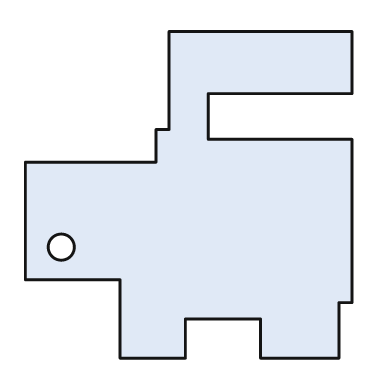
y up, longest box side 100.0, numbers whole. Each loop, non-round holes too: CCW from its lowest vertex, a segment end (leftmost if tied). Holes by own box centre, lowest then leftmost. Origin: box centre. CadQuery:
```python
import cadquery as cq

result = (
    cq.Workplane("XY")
    .moveTo(-21.0, -50.0)
    .lineTo(-1.0, -50.0)
    .lineTo(-1.0, -38.0)
    .lineTo(22.0, -38.0)
    .lineTo(22.0, -50.0)
    .lineTo(46.0, -50.0)
    .lineTo(46.0, -33.0)
    .lineTo(50.0, -33.0)
    .lineTo(50.0, 17.0)
    .lineTo(6.0, 17.0)
    .lineTo(6.0, 31.0)
    .lineTo(50.0, 31.0)
    .lineTo(50.0, 50.0)
    .lineTo(-6.0, 50.0)
    .lineTo(-6.0, 20.0)
    .lineTo(-10.0, 20.0)
    .lineTo(-10.0, 10.0)
    .lineTo(-50.0, 10.0)
    .lineTo(-50.0, -26.0)
    .lineTo(-21.0, -26.0)
    .close()
    .moveTo(-39.0, -16.0)
    .circle(4.0)
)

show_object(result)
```